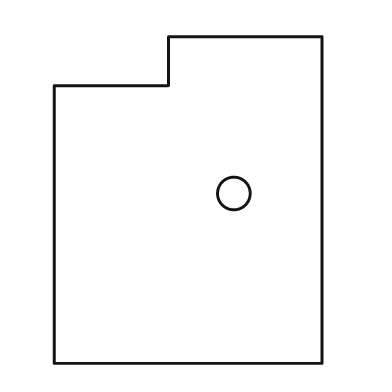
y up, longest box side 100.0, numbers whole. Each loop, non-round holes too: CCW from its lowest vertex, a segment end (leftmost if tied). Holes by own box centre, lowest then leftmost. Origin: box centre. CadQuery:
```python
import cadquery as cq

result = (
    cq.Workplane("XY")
    .moveTo(-41.0, -50.0)
    .lineTo(41.0, -50.0)
    .lineTo(41.0, 50.0)
    .lineTo(-6.0, 50.0)
    .lineTo(-6.0, 35.0)
    .lineTo(-41.0, 35.0)
    .close()
    .moveTo(14.0, 2.0)
    .circle(5.0)
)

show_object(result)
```